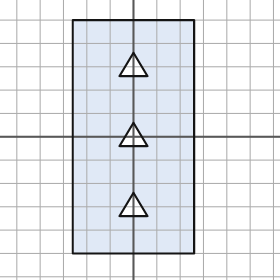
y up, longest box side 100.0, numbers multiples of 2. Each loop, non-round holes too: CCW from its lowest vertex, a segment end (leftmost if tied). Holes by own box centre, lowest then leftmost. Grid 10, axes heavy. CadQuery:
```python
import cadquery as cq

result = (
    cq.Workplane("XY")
    .moveTo(-26.0, -50.0)
    .lineTo(26.0, -50.0)
    .lineTo(26.0, 50.0)
    .lineTo(-26.0, 50.0)
    .close()
    .moveTo(-6.0, -34.0)
    .lineTo(6.0, -34.0)
    .lineTo(0.0, -24.0)
    .close()
    .moveTo(-6.0, -4.0)
    .lineTo(6.0, -4.0)
    .lineTo(0.0, 6.0)
    .close()
    .moveTo(-6.0, 26.0)
    .lineTo(6.0, 26.0)
    .lineTo(0.0, 36.0)
    .close()
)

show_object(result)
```